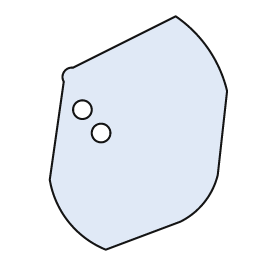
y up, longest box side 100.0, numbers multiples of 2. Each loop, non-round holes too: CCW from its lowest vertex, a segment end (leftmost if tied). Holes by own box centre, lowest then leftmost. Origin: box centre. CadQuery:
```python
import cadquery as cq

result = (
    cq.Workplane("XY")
    .moveTo(-14.0, -50.0)
    .lineTo(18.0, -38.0)
    .threePointArc((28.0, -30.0), (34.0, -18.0))
    .lineTo(38.0, 18.0)
    .threePointArc((30.0, 36.0), (16.0, 50.0))
    .lineTo(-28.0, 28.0)
    .threePointArc((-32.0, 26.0), (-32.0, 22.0))
    .lineTo(-38.0, -20.0)
    .threePointArc((-30.0, -38.0), (-14.0, -50.0))
    .close()
    .moveTo(-16.0, 0.0)
    .circle(4.0)
    .moveTo(-24.0, 10.0)
    .circle(4.0)
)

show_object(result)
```